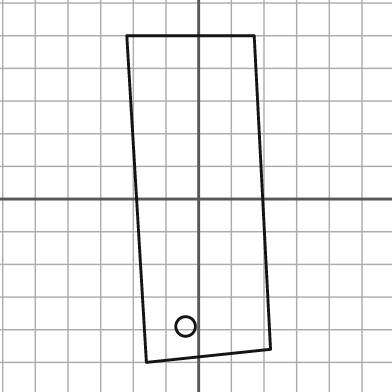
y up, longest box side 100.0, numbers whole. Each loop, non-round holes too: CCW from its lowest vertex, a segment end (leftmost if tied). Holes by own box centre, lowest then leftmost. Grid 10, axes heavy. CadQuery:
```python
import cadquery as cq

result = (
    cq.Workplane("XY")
    .moveTo(-16.0, -50.0)
    .lineTo(22.0, -46.0)
    .lineTo(17.0, 50.0)
    .lineTo(-22.0, 50.0)
    .close()
    .moveTo(-4.0, -39.0)
    .circle(3.0)
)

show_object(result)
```